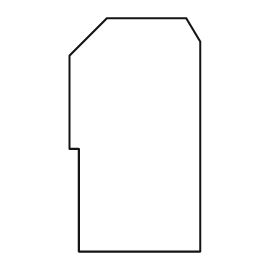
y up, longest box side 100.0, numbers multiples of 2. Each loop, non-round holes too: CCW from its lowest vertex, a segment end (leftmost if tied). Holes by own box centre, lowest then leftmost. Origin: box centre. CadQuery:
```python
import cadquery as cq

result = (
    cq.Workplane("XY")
    .moveTo(-24.0, -50.0)
    .lineTo(28.0, -50.0)
    .lineTo(28.0, 40.0)
    .lineTo(22.0, 50.0)
    .lineTo(-12.0, 50.0)
    .lineTo(-28.0, 34.0)
    .lineTo(-28.0, -6.0)
    .lineTo(-24.0, -6.0)
    .close()
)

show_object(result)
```